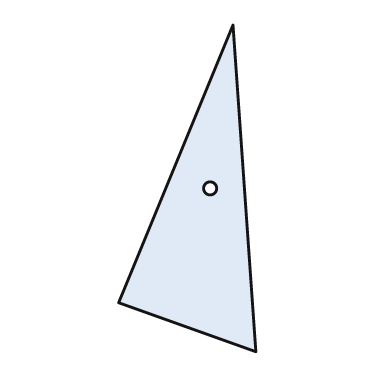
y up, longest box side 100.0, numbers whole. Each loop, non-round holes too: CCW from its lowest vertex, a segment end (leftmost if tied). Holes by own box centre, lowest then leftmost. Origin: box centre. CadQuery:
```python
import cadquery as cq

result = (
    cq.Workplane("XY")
    .moveTo(21.0, -50.0)
    .lineTo(14.0, 50.0)
    .lineTo(-21.0, -35.0)
    .close()
    .moveTo(7.0, 0.0)
    .circle(2.0)
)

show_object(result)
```